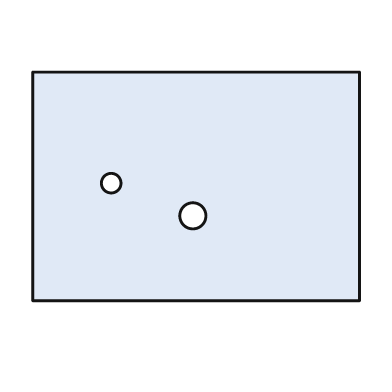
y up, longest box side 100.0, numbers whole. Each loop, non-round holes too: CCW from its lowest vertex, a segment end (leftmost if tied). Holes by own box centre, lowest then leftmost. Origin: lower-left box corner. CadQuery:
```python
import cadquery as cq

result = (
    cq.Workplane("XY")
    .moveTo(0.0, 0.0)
    .lineTo(100.0, 0.0)
    .lineTo(100.0, 70.0)
    .lineTo(0.0, 70.0)
    .close()
    .moveTo(49.0, 26.0)
    .circle(4.0)
    .moveTo(24.0, 36.0)
    .circle(3.0)
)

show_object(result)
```